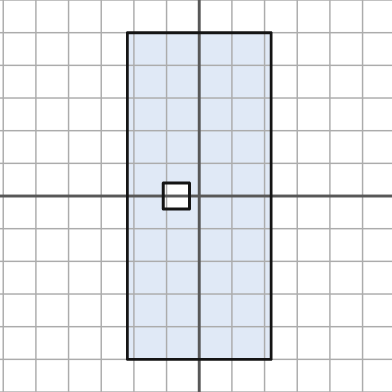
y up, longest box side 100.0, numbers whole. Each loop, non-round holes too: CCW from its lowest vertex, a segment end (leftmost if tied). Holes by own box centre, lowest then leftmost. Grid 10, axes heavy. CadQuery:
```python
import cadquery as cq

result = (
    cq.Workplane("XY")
    .moveTo(-22.0, -50.0)
    .lineTo(22.0, -50.0)
    .lineTo(22.0, 50.0)
    .lineTo(-22.0, 50.0)
    .close()
    .moveTo(-11.0, -4.0)
    .lineTo(-3.0, -4.0)
    .lineTo(-3.0, 4.0)
    .lineTo(-11.0, 4.0)
    .close()
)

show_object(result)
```